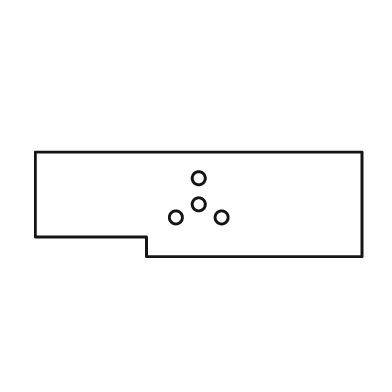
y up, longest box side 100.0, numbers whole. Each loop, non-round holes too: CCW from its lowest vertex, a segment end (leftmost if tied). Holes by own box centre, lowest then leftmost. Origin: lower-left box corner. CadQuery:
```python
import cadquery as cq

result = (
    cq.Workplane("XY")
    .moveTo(34.0, 0.0)
    .lineTo(100.0, 0.0)
    .lineTo(100.0, 32.0)
    .lineTo(0.0, 32.0)
    .lineTo(0.0, 6.0)
    .lineTo(34.0, 6.0)
    .close()
    .moveTo(43.0, 12.0)
    .circle(2.0)
    .moveTo(57.0, 12.0)
    .circle(2.0)
    .moveTo(50.0, 16.0)
    .circle(2.0)
    .moveTo(50.0, 24.0)
    .circle(2.0)
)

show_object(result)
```